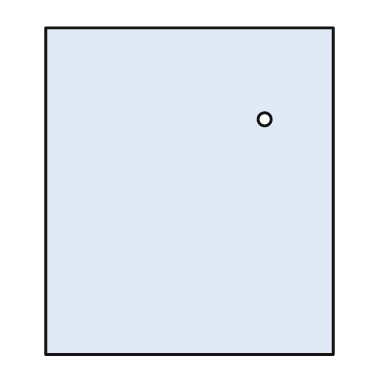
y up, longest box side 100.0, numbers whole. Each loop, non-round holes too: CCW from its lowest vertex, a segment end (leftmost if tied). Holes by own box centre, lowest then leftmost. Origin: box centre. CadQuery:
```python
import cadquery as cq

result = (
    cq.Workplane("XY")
    .moveTo(-44.0, -50.0)
    .lineTo(44.0, -50.0)
    .lineTo(44.0, 50.0)
    .lineTo(-44.0, 50.0)
    .close()
    .moveTo(23.0, 22.0)
    .circle(2.0)
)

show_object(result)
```